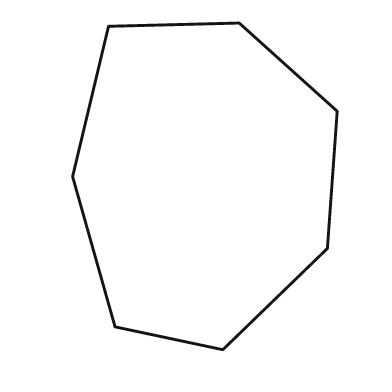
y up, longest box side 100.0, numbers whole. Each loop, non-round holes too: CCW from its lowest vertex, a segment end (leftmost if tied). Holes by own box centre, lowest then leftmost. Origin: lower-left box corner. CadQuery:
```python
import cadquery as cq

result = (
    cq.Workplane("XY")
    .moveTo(46.0, 0.0)
    .lineTo(78.0, 31.0)
    .lineTo(81.0, 73.0)
    .lineTo(51.0, 100.0)
    .lineTo(11.0, 99.0)
    .lineTo(0.0, 53.0)
    .lineTo(13.0, 7.0)
    .close()
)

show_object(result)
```